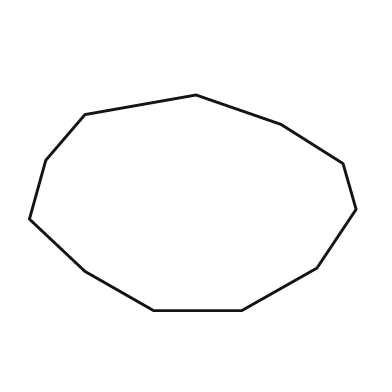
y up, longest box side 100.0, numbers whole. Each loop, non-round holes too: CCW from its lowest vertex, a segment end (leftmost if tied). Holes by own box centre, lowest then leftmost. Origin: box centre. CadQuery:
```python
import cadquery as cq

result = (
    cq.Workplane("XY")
    .moveTo(-12.0, -33.0)
    .lineTo(15.0, -33.0)
    .lineTo(38.0, -20.0)
    .lineTo(50.0, -2.0)
    .lineTo(46.0, 12.0)
    .lineTo(27.0, 24.0)
    .lineTo(1.0, 33.0)
    .lineTo(-33.0, 27.0)
    .lineTo(-45.0, 13.0)
    .lineTo(-50.0, -5.0)
    .lineTo(-33.0, -21.0)
    .close()
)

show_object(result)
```